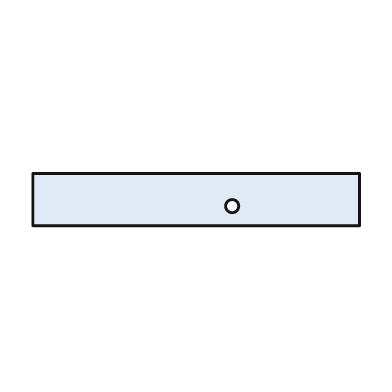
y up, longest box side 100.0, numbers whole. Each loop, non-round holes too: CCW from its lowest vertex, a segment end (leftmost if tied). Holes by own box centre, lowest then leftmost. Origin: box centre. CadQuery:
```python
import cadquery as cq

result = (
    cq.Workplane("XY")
    .moveTo(-50.0, -8.0)
    .lineTo(50.0, -8.0)
    .lineTo(50.0, 8.0)
    .lineTo(-50.0, 8.0)
    .close()
    .moveTo(11.0, -2.0)
    .circle(2.0)
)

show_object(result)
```